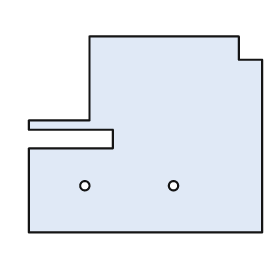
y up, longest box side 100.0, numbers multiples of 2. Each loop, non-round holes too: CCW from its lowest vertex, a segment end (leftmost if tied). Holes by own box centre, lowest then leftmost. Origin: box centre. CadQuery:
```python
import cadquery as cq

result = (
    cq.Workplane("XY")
    .moveTo(-50.0, -42.0)
    .lineTo(50.0, -42.0)
    .lineTo(50.0, 32.0)
    .lineTo(40.0, 32.0)
    .lineTo(40.0, 42.0)
    .lineTo(-24.0, 42.0)
    .lineTo(-24.0, 6.0)
    .lineTo(-50.0, 6.0)
    .lineTo(-50.0, 2.0)
    .lineTo(-14.0, 2.0)
    .lineTo(-14.0, -6.0)
    .lineTo(-50.0, -6.0)
    .close()
    .moveTo(-26.0, -22.0)
    .circle(2.0)
    .moveTo(12.0, -22.0)
    .circle(2.0)
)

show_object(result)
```